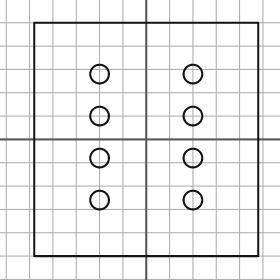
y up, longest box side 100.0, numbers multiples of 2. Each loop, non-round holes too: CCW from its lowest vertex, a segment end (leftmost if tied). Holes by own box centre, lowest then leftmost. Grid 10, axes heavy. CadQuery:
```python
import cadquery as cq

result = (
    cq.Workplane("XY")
    .moveTo(-48.0, -50.0)
    .lineTo(48.0, -50.0)
    .lineTo(48.0, 50.0)
    .lineTo(-48.0, 50.0)
    .close()
    .moveTo(-20.0, -26.0)
    .circle(4.0)
    .moveTo(20.0, -26.0)
    .circle(4.0)
    .moveTo(-20.0, -8.0)
    .circle(4.0)
    .moveTo(20.0, -8.0)
    .circle(4.0)
    .moveTo(-20.0, 10.0)
    .circle(4.0)
    .moveTo(20.0, 10.0)
    .circle(4.0)
    .moveTo(-20.0, 28.0)
    .circle(4.0)
    .moveTo(20.0, 28.0)
    .circle(4.0)
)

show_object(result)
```